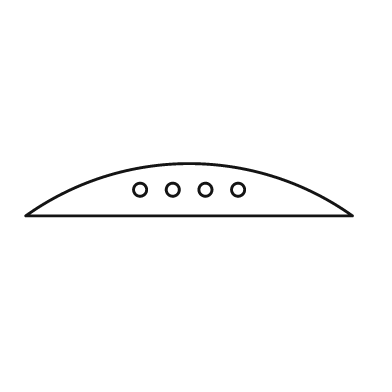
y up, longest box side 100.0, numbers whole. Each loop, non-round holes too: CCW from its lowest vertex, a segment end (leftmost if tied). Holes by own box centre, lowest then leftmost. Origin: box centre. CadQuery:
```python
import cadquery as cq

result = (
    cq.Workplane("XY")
    .moveTo(-50.0, -8.0)
    .lineTo(50.0, -8.0)
    .threePointArc((0.0, 8.0), (-50.0, -8.0))
    .close()
    .moveTo(-15.0, 0.0)
    .circle(2.0)
    .moveTo(-5.0, 0.0)
    .circle(2.0)
    .moveTo(5.0, 0.0)
    .circle(2.0)
    .moveTo(15.0, 0.0)
    .circle(2.0)
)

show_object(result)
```